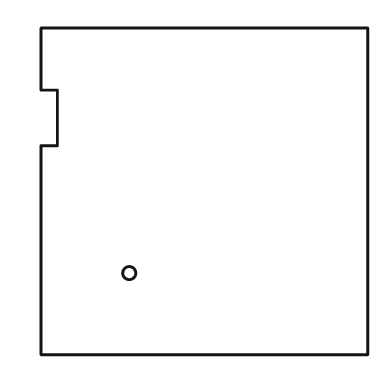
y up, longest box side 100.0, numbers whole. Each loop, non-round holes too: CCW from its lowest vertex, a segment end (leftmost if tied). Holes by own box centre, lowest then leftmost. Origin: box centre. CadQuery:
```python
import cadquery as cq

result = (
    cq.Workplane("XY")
    .moveTo(-50.0, -50.0)
    .lineTo(50.0, -50.0)
    .lineTo(50.0, 50.0)
    .lineTo(-50.0, 50.0)
    .lineTo(-50.0, 31.0)
    .lineTo(-45.0, 31.0)
    .lineTo(-45.0, 14.0)
    .lineTo(-50.0, 14.0)
    .close()
    .moveTo(-23.0, -25.0)
    .circle(2.0)
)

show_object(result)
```